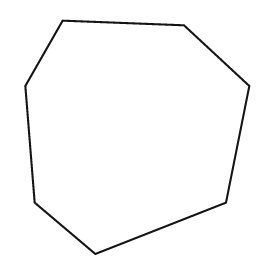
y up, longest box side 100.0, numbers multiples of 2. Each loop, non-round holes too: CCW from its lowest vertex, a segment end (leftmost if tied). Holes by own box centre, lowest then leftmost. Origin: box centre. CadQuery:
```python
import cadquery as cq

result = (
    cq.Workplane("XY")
    .moveTo(-18.0, -50.0)
    .lineTo(38.0, -28.0)
    .lineTo(48.0, 22.0)
    .lineTo(20.0, 48.0)
    .lineTo(-32.0, 50.0)
    .lineTo(-48.0, 22.0)
    .lineTo(-44.0, -28.0)
    .close()
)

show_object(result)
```